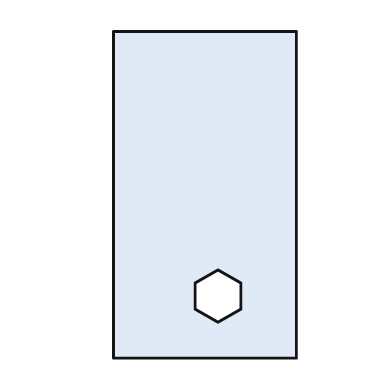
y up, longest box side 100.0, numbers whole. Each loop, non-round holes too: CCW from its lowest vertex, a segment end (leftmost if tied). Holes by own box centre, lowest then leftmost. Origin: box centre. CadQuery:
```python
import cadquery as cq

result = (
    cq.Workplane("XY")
    .moveTo(-28.0, -50.0)
    .lineTo(28.0, -50.0)
    .lineTo(28.0, 50.0)
    .lineTo(-28.0, 50.0)
    .close()
    .moveTo(4.0, -39.0)
    .lineTo(11.0, -35.0)
    .lineTo(11.0, -27.0)
    .lineTo(4.0, -23.0)
    .lineTo(-3.0, -27.0)
    .lineTo(-3.0, -35.0)
    .close()
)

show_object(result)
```